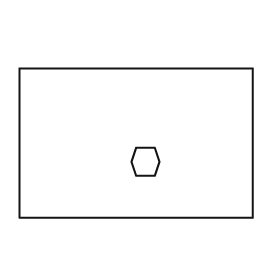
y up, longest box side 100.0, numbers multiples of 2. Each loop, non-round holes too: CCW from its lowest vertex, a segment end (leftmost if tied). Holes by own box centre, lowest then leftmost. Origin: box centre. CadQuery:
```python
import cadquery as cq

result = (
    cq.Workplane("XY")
    .moveTo(-50.0, -32.0)
    .lineTo(50.0, -32.0)
    .lineTo(50.0, 32.0)
    .lineTo(-50.0, 32.0)
    .close()
    .moveTo(0.0, -14.0)
    .lineTo(8.0, -14.0)
    .lineTo(10.0, -8.0)
    .lineTo(8.0, -2.0)
    .lineTo(0.0, -2.0)
    .lineTo(-2.0, -8.0)
    .close()
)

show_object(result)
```